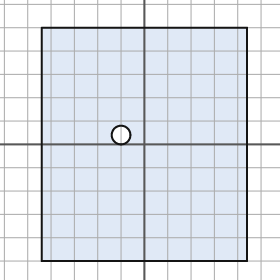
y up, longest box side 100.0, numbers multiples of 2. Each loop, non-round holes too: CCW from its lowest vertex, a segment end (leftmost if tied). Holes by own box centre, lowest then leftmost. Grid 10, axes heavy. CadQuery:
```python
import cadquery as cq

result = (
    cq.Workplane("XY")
    .moveTo(-44.0, -50.0)
    .lineTo(44.0, -50.0)
    .lineTo(44.0, 50.0)
    .lineTo(-44.0, 50.0)
    .close()
    .moveTo(-10.0, 4.0)
    .circle(4.0)
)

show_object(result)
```